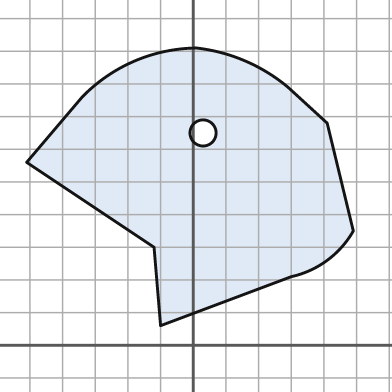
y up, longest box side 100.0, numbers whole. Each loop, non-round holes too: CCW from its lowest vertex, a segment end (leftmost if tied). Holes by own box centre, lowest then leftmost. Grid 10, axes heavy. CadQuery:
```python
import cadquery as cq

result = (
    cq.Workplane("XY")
    .moveTo(-10.0, 6.0)
    .lineTo(30.0, 21.0)
    .threePointArc((41.0, 26.0), (49.0, 35.0))
    .lineTo(41.0, 68.0)
    .lineTo(29.0, 79.0)
    .threePointArc((16.0, 87.0), (1.0, 91.0))
    .threePointArc((-18.0, 87.0), (-34.0, 76.0))
    .lineTo(-51.0, 56.0)
    .lineTo(-12.0, 30.0)
    .close()
    .moveTo(3.0, 65.0)
    .circle(4.0)
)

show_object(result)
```